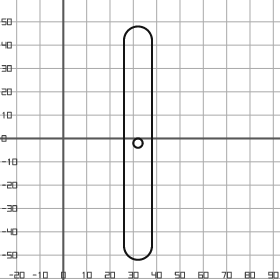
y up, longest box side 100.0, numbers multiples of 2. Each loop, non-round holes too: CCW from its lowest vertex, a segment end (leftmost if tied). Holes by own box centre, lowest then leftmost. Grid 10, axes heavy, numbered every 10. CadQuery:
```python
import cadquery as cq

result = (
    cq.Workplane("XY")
    .moveTo(26.0, -46.0)
    .threePointArc((32.0, -52.0), (38.0, -46.0))
    .lineTo(38.0, 42.0)
    .threePointArc((32.0, 48.0), (26.0, 42.0))
    .close()
    .moveTo(32.0, -2.0)
    .circle(2.0)
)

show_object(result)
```